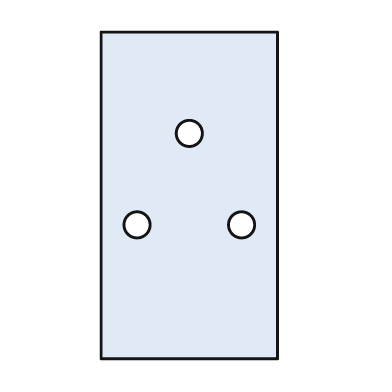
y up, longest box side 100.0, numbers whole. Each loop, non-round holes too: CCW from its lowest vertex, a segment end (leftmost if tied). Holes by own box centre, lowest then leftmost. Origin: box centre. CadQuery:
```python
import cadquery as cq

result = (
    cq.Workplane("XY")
    .moveTo(-27.0, -50.0)
    .lineTo(27.0, -50.0)
    .lineTo(27.0, 50.0)
    .lineTo(-27.0, 50.0)
    .close()
    .moveTo(-16.0, -9.0)
    .circle(4.0)
    .moveTo(16.0, -9.0)
    .circle(4.0)
    .moveTo(0.0, 19.0)
    .circle(4.0)
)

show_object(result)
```